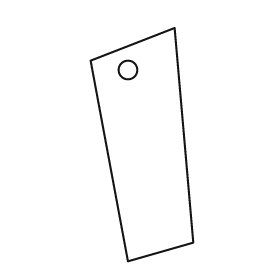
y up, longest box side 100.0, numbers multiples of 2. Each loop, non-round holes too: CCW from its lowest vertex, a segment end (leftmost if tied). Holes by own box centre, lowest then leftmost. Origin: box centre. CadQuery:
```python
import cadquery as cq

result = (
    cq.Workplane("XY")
    .moveTo(-6.0, -50.0)
    .lineTo(22.0, -42.0)
    .lineTo(14.0, 50.0)
    .lineTo(-22.0, 36.0)
    .close()
    .moveTo(-6.0, 32.0)
    .circle(4.0)
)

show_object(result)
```